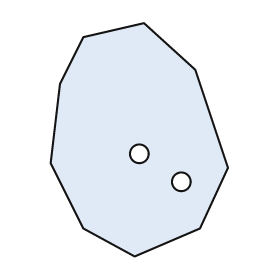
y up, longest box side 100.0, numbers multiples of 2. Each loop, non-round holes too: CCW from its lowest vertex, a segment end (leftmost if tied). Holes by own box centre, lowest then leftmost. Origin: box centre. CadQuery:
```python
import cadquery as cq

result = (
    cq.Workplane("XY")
    .moveTo(-2.0, -50.0)
    .lineTo(26.0, -38.0)
    .lineTo(38.0, -12.0)
    .lineTo(24.0, 30.0)
    .lineTo(2.0, 50.0)
    .lineTo(-24.0, 44.0)
    .lineTo(-34.0, 24.0)
    .lineTo(-38.0, -10.0)
    .lineTo(-24.0, -38.0)
    .close()
    .moveTo(18.0, -18.0)
    .circle(4.0)
    .moveTo(0.0, -6.0)
    .circle(4.0)
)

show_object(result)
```